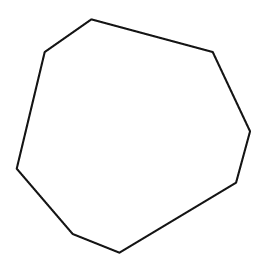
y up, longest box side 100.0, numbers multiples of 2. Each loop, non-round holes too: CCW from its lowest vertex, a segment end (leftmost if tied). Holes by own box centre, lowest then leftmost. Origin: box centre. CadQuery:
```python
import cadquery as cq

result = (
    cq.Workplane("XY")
    .moveTo(-6.0, -50.0)
    .lineTo(44.0, -20.0)
    .lineTo(50.0, 2.0)
    .lineTo(34.0, 36.0)
    .lineTo(-18.0, 50.0)
    .lineTo(-38.0, 36.0)
    .lineTo(-50.0, -14.0)
    .lineTo(-26.0, -42.0)
    .close()
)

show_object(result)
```